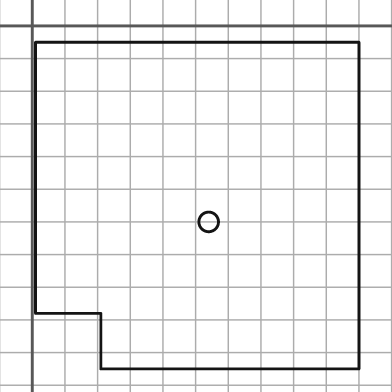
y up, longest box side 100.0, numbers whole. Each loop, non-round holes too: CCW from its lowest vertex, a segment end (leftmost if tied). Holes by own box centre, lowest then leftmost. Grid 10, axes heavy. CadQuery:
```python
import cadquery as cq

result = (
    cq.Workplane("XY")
    .moveTo(21.0, -105.0)
    .lineTo(100.0, -105.0)
    .lineTo(100.0, -5.0)
    .lineTo(1.0, -5.0)
    .lineTo(1.0, -88.0)
    .lineTo(21.0, -88.0)
    .close()
    .moveTo(54.0, -60.0)
    .circle(3.0)
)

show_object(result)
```